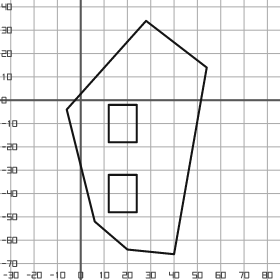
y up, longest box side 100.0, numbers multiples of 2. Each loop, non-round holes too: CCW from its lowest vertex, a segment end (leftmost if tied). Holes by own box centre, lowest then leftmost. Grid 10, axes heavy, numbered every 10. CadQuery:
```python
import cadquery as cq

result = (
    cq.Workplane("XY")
    .moveTo(40.0, -66.0)
    .lineTo(54.0, 14.0)
    .lineTo(28.0, 34.0)
    .lineTo(-6.0, -4.0)
    .lineTo(6.0, -52.0)
    .lineTo(20.0, -64.0)
    .close()
    .moveTo(12.0, -48.0)
    .lineTo(24.0, -48.0)
    .lineTo(24.0, -32.0)
    .lineTo(12.0, -32.0)
    .close()
    .moveTo(12.0, -18.0)
    .lineTo(24.0, -18.0)
    .lineTo(24.0, -2.0)
    .lineTo(12.0, -2.0)
    .close()
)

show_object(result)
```